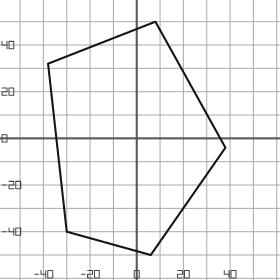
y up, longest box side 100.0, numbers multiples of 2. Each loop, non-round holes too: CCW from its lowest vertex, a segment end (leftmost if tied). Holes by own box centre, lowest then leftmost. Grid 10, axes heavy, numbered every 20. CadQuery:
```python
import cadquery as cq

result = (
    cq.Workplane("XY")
    .moveTo(6.0, -50.0)
    .lineTo(38.0, -4.0)
    .lineTo(8.0, 50.0)
    .lineTo(-38.0, 32.0)
    .lineTo(-30.0, -40.0)
    .close()
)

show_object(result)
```